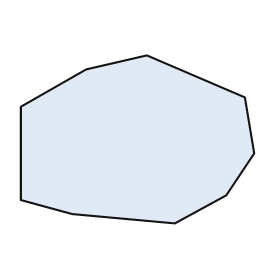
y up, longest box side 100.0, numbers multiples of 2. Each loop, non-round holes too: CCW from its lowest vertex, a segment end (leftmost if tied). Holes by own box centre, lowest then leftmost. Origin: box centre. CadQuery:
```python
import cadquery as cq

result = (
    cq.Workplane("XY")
    .moveTo(16.0, -36.0)
    .lineTo(38.0, -24.0)
    .lineTo(50.0, -6.0)
    .lineTo(46.0, 18.0)
    .lineTo(4.0, 36.0)
    .lineTo(-22.0, 30.0)
    .lineTo(-50.0, 14.0)
    .lineTo(-50.0, -26.0)
    .lineTo(-28.0, -32.0)
    .close()
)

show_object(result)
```